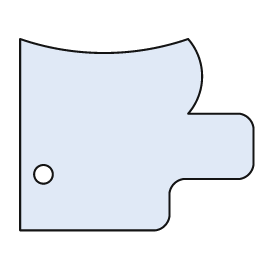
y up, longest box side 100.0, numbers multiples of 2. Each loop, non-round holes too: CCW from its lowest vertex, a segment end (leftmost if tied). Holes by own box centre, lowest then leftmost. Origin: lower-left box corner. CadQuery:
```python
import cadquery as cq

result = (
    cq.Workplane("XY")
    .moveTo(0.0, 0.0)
    .lineTo(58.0, 0.0)
    .threePointArc((62.0, 2.0), (64.0, 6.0))
    .lineTo(64.0, 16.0)
    .threePointArc((66.0, 20.0), (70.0, 22.0))
    .lineTo(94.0, 22.0)
    .threePointArc((98.0, 24.0), (100.0, 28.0))
    .lineTo(100.0, 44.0)
    .threePointArc((98.0, 48.0), (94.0, 50.0))
    .lineTo(72.0, 50.0)
    .threePointArc((78.0, 66.0), (72.0, 82.0))
    .threePointArc((36.0, 76.0), (0.0, 82.0))
    .close()
    .moveTo(10.0, 24.0)
    .circle(4.0)
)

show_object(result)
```